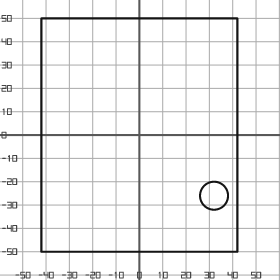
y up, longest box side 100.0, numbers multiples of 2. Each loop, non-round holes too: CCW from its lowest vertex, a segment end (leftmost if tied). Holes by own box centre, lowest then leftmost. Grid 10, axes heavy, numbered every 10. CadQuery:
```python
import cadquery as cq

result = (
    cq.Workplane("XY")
    .moveTo(-42.0, -50.0)
    .lineTo(42.0, -50.0)
    .lineTo(42.0, 50.0)
    .lineTo(-42.0, 50.0)
    .close()
    .moveTo(32.0, -26.0)
    .circle(6.0)
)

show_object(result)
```